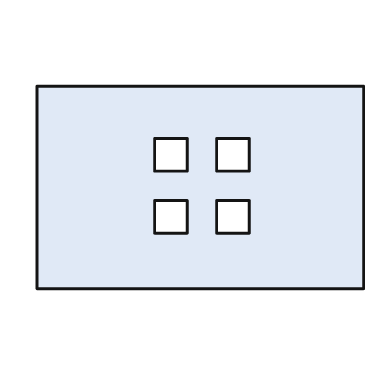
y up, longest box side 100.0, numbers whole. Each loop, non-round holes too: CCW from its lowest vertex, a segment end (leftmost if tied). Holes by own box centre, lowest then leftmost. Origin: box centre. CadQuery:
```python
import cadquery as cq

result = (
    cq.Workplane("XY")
    .moveTo(-50.0, -31.0)
    .lineTo(50.0, -31.0)
    .lineTo(50.0, 31.0)
    .lineTo(-50.0, 31.0)
    .close()
    .moveTo(-14.0, -14.0)
    .lineTo(-4.0, -14.0)
    .lineTo(-4.0, -4.0)
    .lineTo(-14.0, -4.0)
    .close()
    .moveTo(5.0, -14.0)
    .lineTo(15.0, -14.0)
    .lineTo(15.0, -4.0)
    .lineTo(5.0, -4.0)
    .close()
    .moveTo(-14.0, 5.0)
    .lineTo(-4.0, 5.0)
    .lineTo(-4.0, 15.0)
    .lineTo(-14.0, 15.0)
    .close()
    .moveTo(5.0, 5.0)
    .lineTo(15.0, 5.0)
    .lineTo(15.0, 15.0)
    .lineTo(5.0, 15.0)
    .close()
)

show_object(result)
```